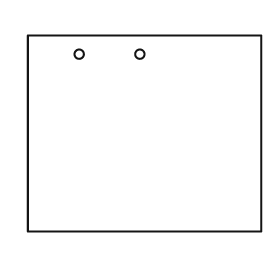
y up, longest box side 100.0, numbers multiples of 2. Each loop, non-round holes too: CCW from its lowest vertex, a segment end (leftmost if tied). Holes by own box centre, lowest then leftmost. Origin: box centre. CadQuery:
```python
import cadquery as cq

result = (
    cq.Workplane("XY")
    .moveTo(-50.0, -42.0)
    .lineTo(50.0, -42.0)
    .lineTo(50.0, 42.0)
    .lineTo(-50.0, 42.0)
    .close()
    .moveTo(-28.0, 34.0)
    .circle(2.0)
    .moveTo(-2.0, 34.0)
    .circle(2.0)
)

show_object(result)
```